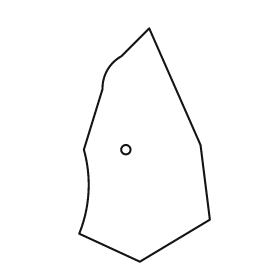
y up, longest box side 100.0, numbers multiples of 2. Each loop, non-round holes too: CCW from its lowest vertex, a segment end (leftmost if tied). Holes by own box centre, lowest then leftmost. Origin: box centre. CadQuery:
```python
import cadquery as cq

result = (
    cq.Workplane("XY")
    .moveTo(-2.0, -50.0)
    .lineTo(28.0, -32.0)
    .lineTo(24.0, 0.0)
    .lineTo(2.0, 50.0)
    .lineTo(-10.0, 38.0)
    .threePointArc((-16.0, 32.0), (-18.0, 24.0))
    .lineTo(-26.0, -2.0)
    .threePointArc((-24.0, -20.0), (-28.0, -38.0))
    .close()
    .moveTo(-8.0, -2.0)
    .circle(2.0)
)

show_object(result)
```